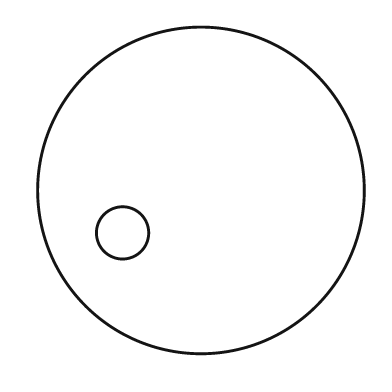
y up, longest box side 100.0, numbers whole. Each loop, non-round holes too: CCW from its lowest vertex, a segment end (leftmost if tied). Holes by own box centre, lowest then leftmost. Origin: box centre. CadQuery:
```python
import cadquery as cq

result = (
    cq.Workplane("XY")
    .moveTo(0.0, 0.0)
    .circle(50.0)
    .moveTo(-24.0, -13.0)
    .circle(8.0)
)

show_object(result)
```